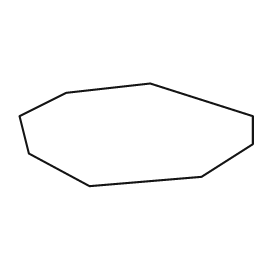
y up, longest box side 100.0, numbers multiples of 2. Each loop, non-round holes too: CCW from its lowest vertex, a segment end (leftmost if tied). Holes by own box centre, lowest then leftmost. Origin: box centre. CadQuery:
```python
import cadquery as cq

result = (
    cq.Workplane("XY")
    .moveTo(-20.0, -22.0)
    .lineTo(28.0, -18.0)
    .lineTo(50.0, -4.0)
    .lineTo(50.0, 8.0)
    .lineTo(6.0, 22.0)
    .lineTo(-30.0, 18.0)
    .lineTo(-50.0, 8.0)
    .lineTo(-46.0, -8.0)
    .close()
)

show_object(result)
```